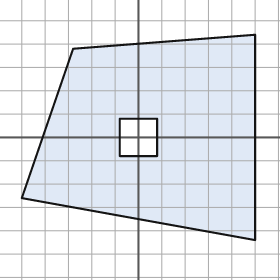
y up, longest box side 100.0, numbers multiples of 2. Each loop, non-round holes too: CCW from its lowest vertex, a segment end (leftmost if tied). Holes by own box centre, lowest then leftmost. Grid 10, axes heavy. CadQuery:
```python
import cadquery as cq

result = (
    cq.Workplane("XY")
    .moveTo(50.0, -44.0)
    .lineTo(50.0, 44.0)
    .lineTo(-28.0, 38.0)
    .lineTo(-50.0, -26.0)
    .close()
    .moveTo(-8.0, -8.0)
    .lineTo(8.0, -8.0)
    .lineTo(8.0, 8.0)
    .lineTo(-8.0, 8.0)
    .close()
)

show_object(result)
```